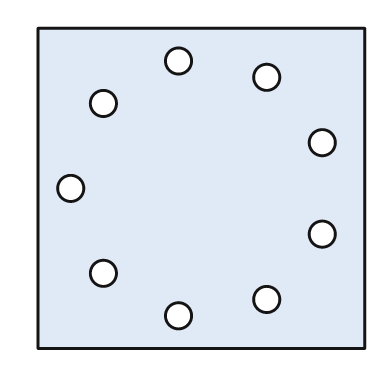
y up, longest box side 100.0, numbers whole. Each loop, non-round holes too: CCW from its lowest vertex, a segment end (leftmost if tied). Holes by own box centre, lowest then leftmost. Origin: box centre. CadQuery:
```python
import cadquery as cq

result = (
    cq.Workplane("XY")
    .moveTo(-50.0, -49.0)
    .lineTo(50.0, -49.0)
    .lineTo(50.0, 49.0)
    .lineTo(-50.0, 49.0)
    .close()
    .moveTo(-7.0, -39.0)
    .circle(4.0)
    .moveTo(20.0, -34.0)
    .circle(4.0)
    .moveTo(-30.0, -26.0)
    .circle(4.0)
    .moveTo(37.0, -14.0)
    .circle(4.0)
    .moveTo(-40.0, 0.0)
    .circle(4.0)
    .moveTo(37.0, 14.0)
    .circle(4.0)
    .moveTo(-30.0, 26.0)
    .circle(4.0)
    .moveTo(20.0, 34.0)
    .circle(4.0)
    .moveTo(-7.0, 39.0)
    .circle(4.0)
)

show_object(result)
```